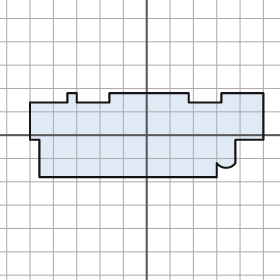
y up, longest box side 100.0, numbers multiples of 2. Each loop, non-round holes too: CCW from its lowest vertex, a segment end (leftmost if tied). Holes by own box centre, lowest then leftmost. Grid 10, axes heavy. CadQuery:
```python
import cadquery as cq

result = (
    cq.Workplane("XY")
    .moveTo(-46.0, -18.0)
    .lineTo(30.0, -18.0)
    .lineTo(30.0, -12.0)
    .threePointArc((34.0, -14.0), (38.0, -12.0))
    .lineTo(38.0, -2.0)
    .lineTo(50.0, -2.0)
    .lineTo(50.0, 18.0)
    .lineTo(32.0, 18.0)
    .lineTo(32.0, 14.0)
    .lineTo(18.0, 14.0)
    .lineTo(18.0, 18.0)
    .lineTo(-16.0, 18.0)
    .lineTo(-16.0, 14.0)
    .lineTo(-30.0, 14.0)
    .lineTo(-30.0, 18.0)
    .lineTo(-34.0, 18.0)
    .lineTo(-34.0, 14.0)
    .lineTo(-50.0, 14.0)
    .lineTo(-50.0, -2.0)
    .lineTo(-46.0, -2.0)
    .close()
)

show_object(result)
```